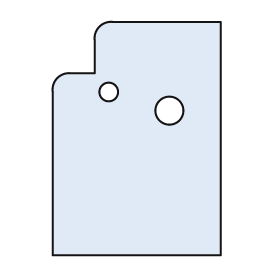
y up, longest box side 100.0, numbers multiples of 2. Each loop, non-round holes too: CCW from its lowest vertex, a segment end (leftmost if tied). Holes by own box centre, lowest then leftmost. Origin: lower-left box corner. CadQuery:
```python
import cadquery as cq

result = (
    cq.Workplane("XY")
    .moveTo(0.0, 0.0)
    .lineTo(72.0, 0.0)
    .lineTo(72.0, 100.0)
    .lineTo(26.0, 100.0)
    .threePointArc((20.0, 98.0), (18.0, 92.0))
    .lineTo(18.0, 78.0)
    .lineTo(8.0, 78.0)
    .threePointArc((2.0, 76.0), (0.0, 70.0))
    .close()
    .moveTo(50.0, 62.0)
    .circle(6.0)
    .moveTo(24.0, 70.0)
    .circle(4.0)
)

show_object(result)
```